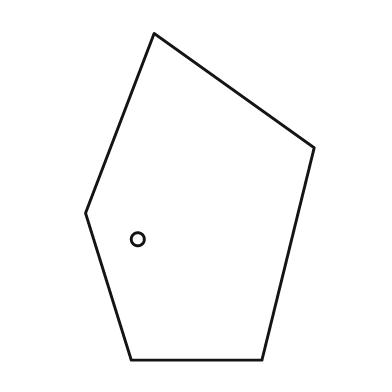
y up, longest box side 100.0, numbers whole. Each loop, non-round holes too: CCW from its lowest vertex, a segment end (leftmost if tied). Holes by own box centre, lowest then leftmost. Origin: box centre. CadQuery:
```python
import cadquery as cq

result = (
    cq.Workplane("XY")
    .moveTo(-21.0, -50.0)
    .lineTo(19.0, -50.0)
    .lineTo(35.0, 15.0)
    .lineTo(-14.0, 50.0)
    .lineTo(-35.0, -5.0)
    .close()
    .moveTo(-19.0, -13.0)
    .circle(2.0)
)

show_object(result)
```